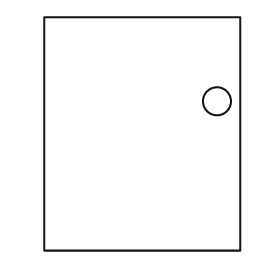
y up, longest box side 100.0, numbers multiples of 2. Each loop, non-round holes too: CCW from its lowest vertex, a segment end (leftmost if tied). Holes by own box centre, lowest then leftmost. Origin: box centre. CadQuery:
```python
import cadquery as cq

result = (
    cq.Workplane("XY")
    .moveTo(-42.0, -50.0)
    .lineTo(42.0, -50.0)
    .lineTo(42.0, 50.0)
    .lineTo(-42.0, 50.0)
    .close()
    .moveTo(32.0, 14.0)
    .circle(6.0)
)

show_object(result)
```